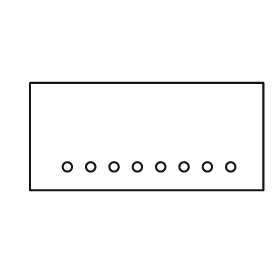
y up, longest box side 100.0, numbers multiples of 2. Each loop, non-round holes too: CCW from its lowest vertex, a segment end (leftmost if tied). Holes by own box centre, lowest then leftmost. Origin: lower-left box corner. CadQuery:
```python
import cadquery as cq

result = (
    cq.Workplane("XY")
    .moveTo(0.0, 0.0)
    .lineTo(100.0, 0.0)
    .lineTo(100.0, 46.0)
    .lineTo(0.0, 46.0)
    .close()
    .moveTo(16.0, 10.0)
    .circle(2.0)
    .moveTo(26.0, 10.0)
    .circle(2.0)
    .moveTo(36.0, 10.0)
    .circle(2.0)
    .moveTo(46.0, 10.0)
    .circle(2.0)
    .moveTo(56.0, 10.0)
    .circle(2.0)
    .moveTo(66.0, 10.0)
    .circle(2.0)
    .moveTo(76.0, 10.0)
    .circle(2.0)
    .moveTo(86.0, 10.0)
    .circle(2.0)
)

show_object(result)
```